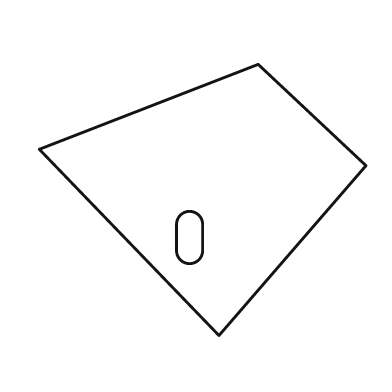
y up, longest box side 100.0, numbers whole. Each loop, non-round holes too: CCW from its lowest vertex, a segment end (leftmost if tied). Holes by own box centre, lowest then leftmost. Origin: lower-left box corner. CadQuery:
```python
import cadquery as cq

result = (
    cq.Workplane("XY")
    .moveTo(55.0, 0.0)
    .lineTo(100.0, 52.0)
    .lineTo(67.0, 83.0)
    .lineTo(0.0, 57.0)
    .close()
    .moveTo(42.0, 26.0)
    .threePointArc((46.0, 22.0), (50.0, 26.0))
    .lineTo(50.0, 34.0)
    .threePointArc((46.0, 38.0), (42.0, 34.0))
    .close()
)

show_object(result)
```